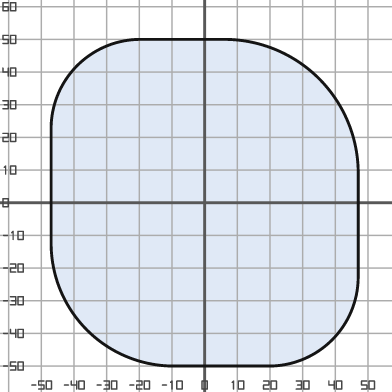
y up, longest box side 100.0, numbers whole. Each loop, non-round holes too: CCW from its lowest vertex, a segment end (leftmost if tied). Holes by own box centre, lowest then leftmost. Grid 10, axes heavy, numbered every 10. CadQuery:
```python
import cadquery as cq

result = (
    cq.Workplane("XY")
    .moveTo(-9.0, -50.0)
    .lineTo(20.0, -50.0)
    .threePointArc((39.0, -42.0), (47.0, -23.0))
    .lineTo(47.0, 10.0)
    .threePointArc((35.0, 38.0), (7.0, 50.0))
    .lineTo(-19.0, 50.0)
    .threePointArc((-39.0, 42.0), (-47.0, 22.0))
    .lineTo(-47.0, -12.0)
    .threePointArc((-36.0, -39.0), (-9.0, -50.0))
    .close()
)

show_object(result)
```